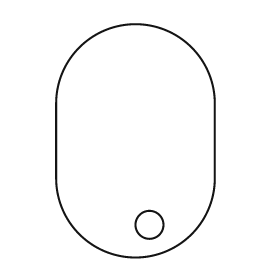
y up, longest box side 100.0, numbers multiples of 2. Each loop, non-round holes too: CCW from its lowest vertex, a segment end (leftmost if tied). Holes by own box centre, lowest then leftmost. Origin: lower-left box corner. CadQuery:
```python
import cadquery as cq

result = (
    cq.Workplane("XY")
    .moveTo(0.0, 34.0)
    .threePointArc((34.0, 0.0), (68.0, 34.0))
    .lineTo(68.0, 66.0)
    .threePointArc((34.0, 100.0), (0.0, 66.0))
    .close()
    .moveTo(40.0, 14.0)
    .circle(6.0)
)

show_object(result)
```